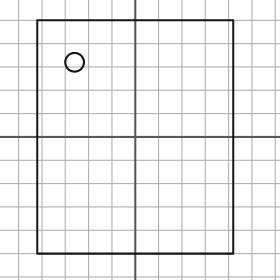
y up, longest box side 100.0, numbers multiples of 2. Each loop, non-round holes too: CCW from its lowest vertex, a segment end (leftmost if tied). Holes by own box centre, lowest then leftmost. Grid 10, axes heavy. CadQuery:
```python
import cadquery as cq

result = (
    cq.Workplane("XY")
    .moveTo(-42.0, -50.0)
    .lineTo(42.0, -50.0)
    .lineTo(42.0, 50.0)
    .lineTo(-42.0, 50.0)
    .close()
    .moveTo(-26.0, 32.0)
    .circle(4.0)
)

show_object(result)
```